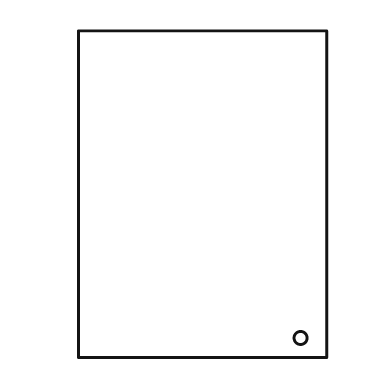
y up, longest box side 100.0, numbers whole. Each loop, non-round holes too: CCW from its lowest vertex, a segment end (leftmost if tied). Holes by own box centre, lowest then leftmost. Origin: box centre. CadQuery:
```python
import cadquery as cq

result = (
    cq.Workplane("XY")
    .moveTo(-38.0, -50.0)
    .lineTo(38.0, -50.0)
    .lineTo(38.0, 50.0)
    .lineTo(-38.0, 50.0)
    .close()
    .moveTo(30.0, -44.0)
    .circle(2.0)
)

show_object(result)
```